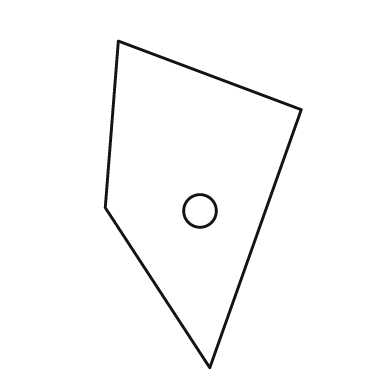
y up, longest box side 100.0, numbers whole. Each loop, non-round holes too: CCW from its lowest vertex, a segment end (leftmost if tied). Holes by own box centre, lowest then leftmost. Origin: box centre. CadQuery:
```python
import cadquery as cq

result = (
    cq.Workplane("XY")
    .moveTo(2.0, -50.0)
    .lineTo(30.0, 29.0)
    .lineTo(-26.0, 50.0)
    .lineTo(-30.0, -1.0)
    .close()
    .moveTo(-1.0, -2.0)
    .circle(5.0)
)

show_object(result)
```